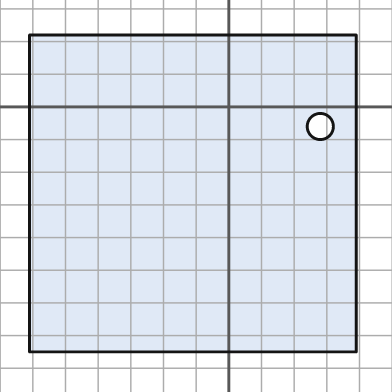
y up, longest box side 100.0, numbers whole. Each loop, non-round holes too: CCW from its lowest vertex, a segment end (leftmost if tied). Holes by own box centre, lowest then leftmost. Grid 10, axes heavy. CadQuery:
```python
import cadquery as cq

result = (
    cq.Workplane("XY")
    .moveTo(-61.0, -75.0)
    .lineTo(39.0, -75.0)
    .lineTo(39.0, 22.0)
    .lineTo(-61.0, 22.0)
    .close()
    .moveTo(28.0, -6.0)
    .circle(4.0)
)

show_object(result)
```